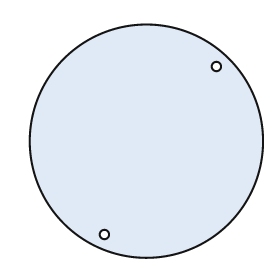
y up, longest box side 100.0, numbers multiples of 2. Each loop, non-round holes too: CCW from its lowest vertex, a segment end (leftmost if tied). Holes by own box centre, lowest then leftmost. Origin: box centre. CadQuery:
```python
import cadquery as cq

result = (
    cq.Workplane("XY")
    .moveTo(0.0, 0.0)
    .circle(50.0)
    .moveTo(-18.0, -40.0)
    .circle(2.0)
    .moveTo(30.0, 32.0)
    .circle(2.0)
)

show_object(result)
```